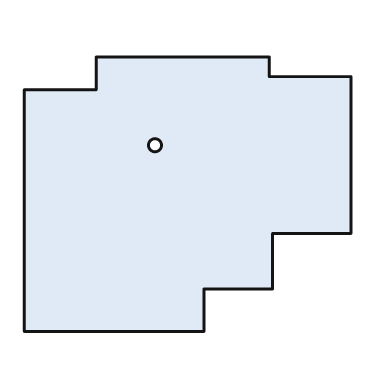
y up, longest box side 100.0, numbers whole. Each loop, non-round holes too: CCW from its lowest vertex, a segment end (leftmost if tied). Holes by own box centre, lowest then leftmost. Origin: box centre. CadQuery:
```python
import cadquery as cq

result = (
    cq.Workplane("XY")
    .moveTo(-50.0, -42.0)
    .lineTo(5.0, -42.0)
    .lineTo(5.0, -29.0)
    .lineTo(26.0, -29.0)
    .lineTo(26.0, -12.0)
    .lineTo(50.0, -12.0)
    .lineTo(50.0, 36.0)
    .lineTo(25.0, 36.0)
    .lineTo(25.0, 42.0)
    .lineTo(-28.0, 42.0)
    .lineTo(-28.0, 32.0)
    .lineTo(-50.0, 32.0)
    .close()
    .moveTo(-10.0, 15.0)
    .circle(2.0)
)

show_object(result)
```